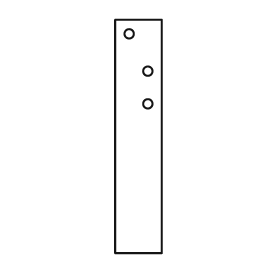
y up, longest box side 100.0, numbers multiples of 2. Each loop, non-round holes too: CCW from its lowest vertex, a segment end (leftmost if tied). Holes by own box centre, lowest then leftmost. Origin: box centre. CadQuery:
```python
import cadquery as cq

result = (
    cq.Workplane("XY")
    .moveTo(-10.0, -50.0)
    .lineTo(10.0, -50.0)
    .lineTo(10.0, 50.0)
    .lineTo(-10.0, 50.0)
    .close()
    .moveTo(4.0, 14.0)
    .circle(2.0)
    .moveTo(4.0, 28.0)
    .circle(2.0)
    .moveTo(-4.0, 44.0)
    .circle(2.0)
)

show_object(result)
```